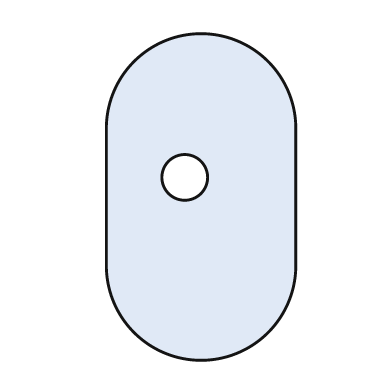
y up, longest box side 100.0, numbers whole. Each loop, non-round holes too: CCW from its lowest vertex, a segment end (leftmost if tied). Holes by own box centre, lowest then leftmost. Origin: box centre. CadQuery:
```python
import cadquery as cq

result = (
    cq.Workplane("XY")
    .moveTo(-29.0, -21.0)
    .threePointArc((0.0, -50.0), (29.0, -21.0))
    .lineTo(29.0, 21.0)
    .threePointArc((0.0, 50.0), (-29.0, 21.0))
    .close()
    .moveTo(-5.0, 6.0)
    .circle(7.0)
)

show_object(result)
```